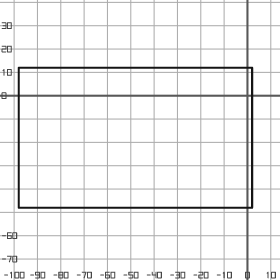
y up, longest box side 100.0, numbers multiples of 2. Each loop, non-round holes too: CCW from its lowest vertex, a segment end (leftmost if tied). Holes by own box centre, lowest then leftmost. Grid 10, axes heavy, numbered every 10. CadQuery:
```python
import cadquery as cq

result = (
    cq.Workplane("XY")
    .moveTo(-98.0, -48.0)
    .lineTo(2.0, -48.0)
    .lineTo(2.0, 12.0)
    .lineTo(-98.0, 12.0)
    .close()
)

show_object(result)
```